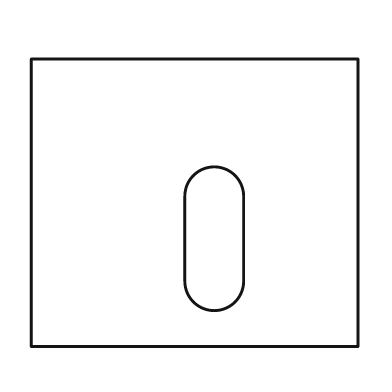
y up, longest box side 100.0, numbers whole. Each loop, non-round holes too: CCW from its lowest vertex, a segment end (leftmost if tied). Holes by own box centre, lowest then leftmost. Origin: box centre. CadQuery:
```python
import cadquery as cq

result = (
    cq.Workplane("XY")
    .moveTo(-50.0, -44.0)
    .lineTo(50.0, -44.0)
    .lineTo(50.0, 44.0)
    .lineTo(-50.0, 44.0)
    .close()
    .moveTo(-3.0, -24.0)
    .threePointArc((6.0, -33.0), (15.0, -24.0))
    .lineTo(15.0, 2.0)
    .threePointArc((6.0, 11.0), (-3.0, 2.0))
    .close()
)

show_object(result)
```